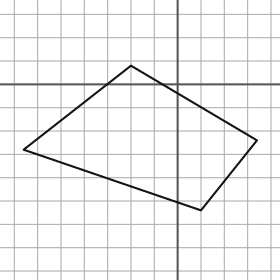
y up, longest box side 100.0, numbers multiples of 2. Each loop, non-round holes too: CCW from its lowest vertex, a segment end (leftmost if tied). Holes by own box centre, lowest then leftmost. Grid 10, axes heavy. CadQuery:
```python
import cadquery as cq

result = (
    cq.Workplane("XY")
    .moveTo(10.0, -54.0)
    .lineTo(34.0, -24.0)
    .lineTo(-20.0, 8.0)
    .lineTo(-66.0, -28.0)
    .close()
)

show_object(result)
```